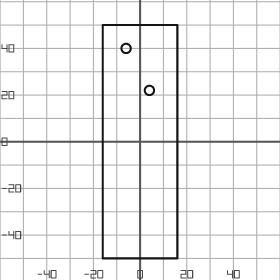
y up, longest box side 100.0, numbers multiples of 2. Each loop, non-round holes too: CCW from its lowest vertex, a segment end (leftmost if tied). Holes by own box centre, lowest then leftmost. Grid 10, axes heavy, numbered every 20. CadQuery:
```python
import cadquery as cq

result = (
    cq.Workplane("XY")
    .moveTo(-16.0, -50.0)
    .lineTo(16.0, -50.0)
    .lineTo(16.0, 50.0)
    .lineTo(-16.0, 50.0)
    .close()
    .moveTo(4.0, 22.0)
    .circle(2.0)
    .moveTo(-6.0, 40.0)
    .circle(2.0)
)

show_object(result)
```